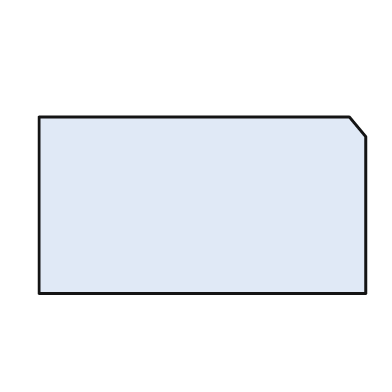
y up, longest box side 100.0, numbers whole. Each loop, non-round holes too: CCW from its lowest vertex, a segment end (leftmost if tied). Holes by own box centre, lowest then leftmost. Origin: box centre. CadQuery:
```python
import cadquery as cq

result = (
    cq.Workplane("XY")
    .moveTo(-50.0, -27.0)
    .lineTo(50.0, -27.0)
    .lineTo(50.0, 21.0)
    .lineTo(45.0, 27.0)
    .lineTo(-50.0, 27.0)
    .close()
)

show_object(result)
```